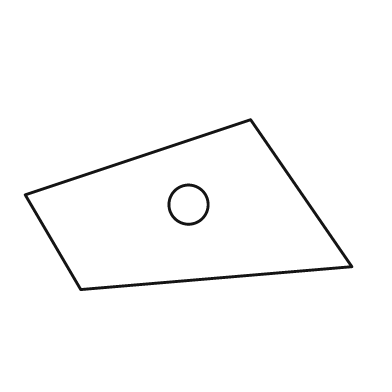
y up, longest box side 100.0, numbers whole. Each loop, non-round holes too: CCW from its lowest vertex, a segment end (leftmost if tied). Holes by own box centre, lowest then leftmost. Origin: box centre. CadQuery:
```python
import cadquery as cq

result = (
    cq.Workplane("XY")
    .moveTo(-33.0, -26.0)
    .lineTo(50.0, -19.0)
    .lineTo(19.0, 26.0)
    .lineTo(-50.0, 3.0)
    .close()
    .moveTo(0.0, 0.0)
    .circle(6.0)
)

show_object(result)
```